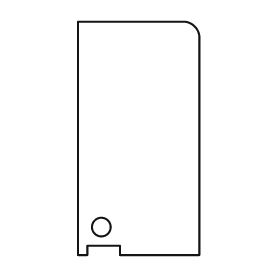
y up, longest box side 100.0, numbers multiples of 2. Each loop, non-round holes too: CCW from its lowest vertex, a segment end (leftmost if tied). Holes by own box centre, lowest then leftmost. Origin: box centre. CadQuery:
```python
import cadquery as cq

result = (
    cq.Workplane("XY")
    .moveTo(-26.0, -50.0)
    .lineTo(-22.0, -50.0)
    .lineTo(-22.0, -46.0)
    .lineTo(-8.0, -46.0)
    .lineTo(-8.0, -50.0)
    .lineTo(26.0, -50.0)
    .lineTo(26.0, 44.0)
    .threePointArc((24.0, 48.0), (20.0, 50.0))
    .lineTo(-26.0, 50.0)
    .close()
    .moveTo(-16.0, -38.0)
    .circle(4.0)
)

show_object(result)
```